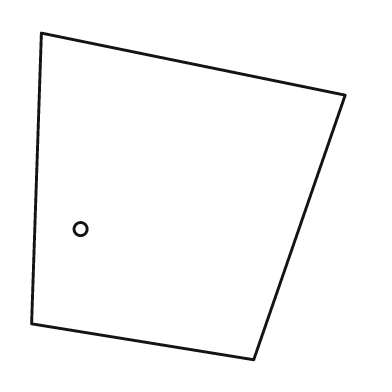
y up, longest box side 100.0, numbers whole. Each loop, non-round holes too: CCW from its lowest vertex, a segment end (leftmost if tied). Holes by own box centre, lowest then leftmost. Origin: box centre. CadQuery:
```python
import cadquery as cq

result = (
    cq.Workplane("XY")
    .moveTo(20.0, -50.0)
    .lineTo(48.0, 31.0)
    .lineTo(-45.0, 50.0)
    .lineTo(-48.0, -39.0)
    .close()
    .moveTo(-33.0, -10.0)
    .circle(2.0)
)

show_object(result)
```